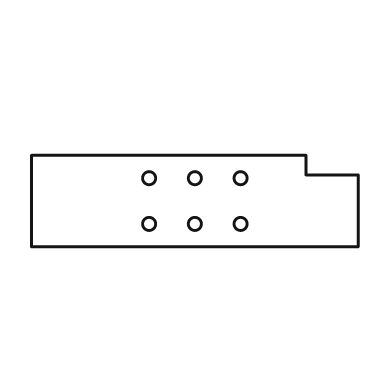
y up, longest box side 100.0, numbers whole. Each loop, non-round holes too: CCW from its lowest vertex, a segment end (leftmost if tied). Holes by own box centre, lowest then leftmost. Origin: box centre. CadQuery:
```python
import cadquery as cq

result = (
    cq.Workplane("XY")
    .moveTo(-50.0, -14.0)
    .lineTo(50.0, -14.0)
    .lineTo(50.0, 8.0)
    .lineTo(34.0, 8.0)
    .lineTo(34.0, 14.0)
    .lineTo(-50.0, 14.0)
    .close()
    .moveTo(-14.0, -7.0)
    .circle(2.0)
    .moveTo(0.0, -7.0)
    .circle(2.0)
    .moveTo(14.0, -7.0)
    .circle(2.0)
    .moveTo(-14.0, 7.0)
    .circle(2.0)
    .moveTo(0.0, 7.0)
    .circle(2.0)
    .moveTo(14.0, 7.0)
    .circle(2.0)
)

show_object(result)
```